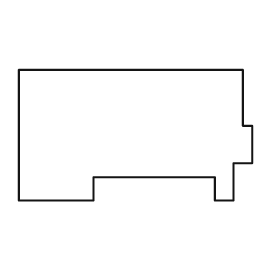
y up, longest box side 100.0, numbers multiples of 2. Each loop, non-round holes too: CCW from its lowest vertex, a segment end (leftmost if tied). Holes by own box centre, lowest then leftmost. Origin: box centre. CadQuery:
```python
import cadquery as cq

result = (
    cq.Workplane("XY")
    .moveTo(-50.0, -28.0)
    .lineTo(-18.0, -28.0)
    .lineTo(-18.0, -18.0)
    .lineTo(34.0, -18.0)
    .lineTo(34.0, -28.0)
    .lineTo(42.0, -28.0)
    .lineTo(42.0, -12.0)
    .lineTo(50.0, -12.0)
    .lineTo(50.0, 4.0)
    .lineTo(46.0, 4.0)
    .lineTo(46.0, 28.0)
    .lineTo(-50.0, 28.0)
    .close()
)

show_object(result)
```